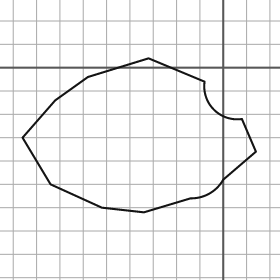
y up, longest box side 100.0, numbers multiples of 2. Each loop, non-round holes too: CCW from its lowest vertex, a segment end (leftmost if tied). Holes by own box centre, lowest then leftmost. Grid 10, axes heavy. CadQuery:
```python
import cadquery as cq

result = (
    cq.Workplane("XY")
    .moveTo(-34.0, -62.0)
    .lineTo(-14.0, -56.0)
    .threePointArc((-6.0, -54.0), (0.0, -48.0))
    .lineTo(14.0, -36.0)
    .lineTo(8.0, -22.0)
    .threePointArc((-4.0, -18.0), (-8.0, -6.0))
    .lineTo(-32.0, 4.0)
    .lineTo(-58.0, -4.0)
    .lineTo(-72.0, -14.0)
    .lineTo(-86.0, -30.0)
    .lineTo(-74.0, -50.0)
    .lineTo(-52.0, -60.0)
    .close()
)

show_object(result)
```